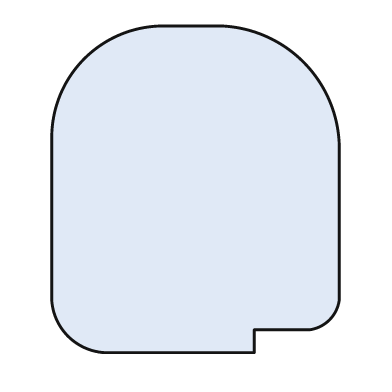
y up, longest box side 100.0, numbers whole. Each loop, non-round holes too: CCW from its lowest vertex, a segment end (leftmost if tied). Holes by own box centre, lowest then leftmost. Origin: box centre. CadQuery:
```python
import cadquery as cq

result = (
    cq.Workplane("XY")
    .moveTo(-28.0, -50.0)
    .lineTo(18.0, -50.0)
    .lineTo(18.0, -43.0)
    .lineTo(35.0, -43.0)
    .threePointArc((41.0, -40.0), (44.0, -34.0))
    .lineTo(44.0, 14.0)
    .threePointArc((33.0, 39.0), (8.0, 50.0))
    .lineTo(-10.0, 50.0)
    .threePointArc((-34.0, 40.0), (-44.0, 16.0))
    .lineTo(-44.0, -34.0)
    .threePointArc((-39.0, -45.0), (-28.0, -50.0))
    .close()
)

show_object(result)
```